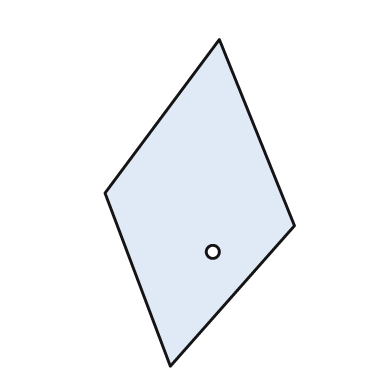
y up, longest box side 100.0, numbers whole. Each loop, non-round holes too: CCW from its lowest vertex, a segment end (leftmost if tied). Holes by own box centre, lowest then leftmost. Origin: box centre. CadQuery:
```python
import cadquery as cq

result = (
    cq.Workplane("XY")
    .moveTo(-9.0, -50.0)
    .lineTo(29.0, -7.0)
    .lineTo(6.0, 50.0)
    .lineTo(-29.0, 3.0)
    .close()
    .moveTo(4.0, -15.0)
    .circle(2.0)
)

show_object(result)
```